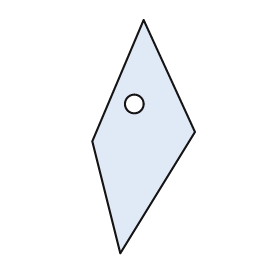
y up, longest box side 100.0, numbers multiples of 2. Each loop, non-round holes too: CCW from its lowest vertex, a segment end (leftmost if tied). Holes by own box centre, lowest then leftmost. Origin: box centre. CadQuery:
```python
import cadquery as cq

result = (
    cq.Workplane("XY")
    .moveTo(-10.0, -50.0)
    .lineTo(22.0, 2.0)
    .lineTo(0.0, 50.0)
    .lineTo(-22.0, -2.0)
    .close()
    .moveTo(-4.0, 14.0)
    .circle(4.0)
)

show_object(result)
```